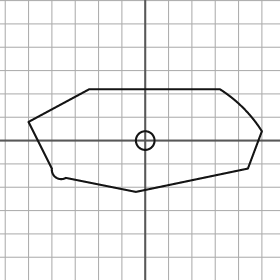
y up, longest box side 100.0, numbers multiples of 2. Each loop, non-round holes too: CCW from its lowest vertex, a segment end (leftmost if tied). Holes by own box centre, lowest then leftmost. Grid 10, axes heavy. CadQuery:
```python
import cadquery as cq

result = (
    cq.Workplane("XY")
    .moveTo(-4.0, -22.0)
    .lineTo(44.0, -12.0)
    .lineTo(50.0, 4.0)
    .threePointArc((42.0, 14.0), (32.0, 22.0))
    .lineTo(-24.0, 22.0)
    .lineTo(-50.0, 8.0)
    .lineTo(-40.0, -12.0)
    .threePointArc((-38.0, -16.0), (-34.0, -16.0))
    .close()
    .moveTo(0.0, 0.0)
    .circle(4.0)
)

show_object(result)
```